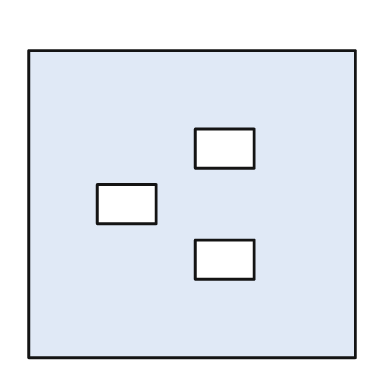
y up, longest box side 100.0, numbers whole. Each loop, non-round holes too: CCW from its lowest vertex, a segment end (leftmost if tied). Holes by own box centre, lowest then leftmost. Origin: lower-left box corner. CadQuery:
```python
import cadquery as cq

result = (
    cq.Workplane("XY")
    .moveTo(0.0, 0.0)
    .lineTo(100.0, 0.0)
    .lineTo(100.0, 94.0)
    .lineTo(0.0, 94.0)
    .close()
    .moveTo(51.0, 24.0)
    .lineTo(69.0, 24.0)
    .lineTo(69.0, 36.0)
    .lineTo(51.0, 36.0)
    .close()
    .moveTo(21.0, 41.0)
    .lineTo(39.0, 41.0)
    .lineTo(39.0, 53.0)
    .lineTo(21.0, 53.0)
    .close()
    .moveTo(51.0, 58.0)
    .lineTo(69.0, 58.0)
    .lineTo(69.0, 70.0)
    .lineTo(51.0, 70.0)
    .close()
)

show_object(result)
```